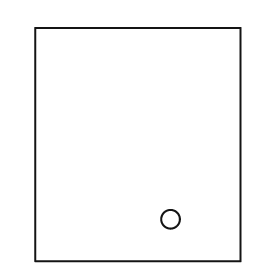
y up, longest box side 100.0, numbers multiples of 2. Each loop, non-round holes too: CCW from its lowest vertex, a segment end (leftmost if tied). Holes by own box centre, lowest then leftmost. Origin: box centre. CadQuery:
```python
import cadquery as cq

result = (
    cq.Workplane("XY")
    .moveTo(-44.0, -50.0)
    .lineTo(44.0, -50.0)
    .lineTo(44.0, 50.0)
    .lineTo(-44.0, 50.0)
    .close()
    .moveTo(14.0, -32.0)
    .circle(4.0)
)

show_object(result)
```